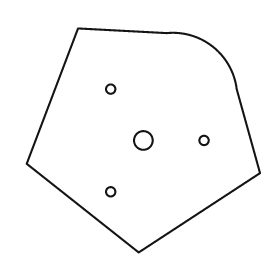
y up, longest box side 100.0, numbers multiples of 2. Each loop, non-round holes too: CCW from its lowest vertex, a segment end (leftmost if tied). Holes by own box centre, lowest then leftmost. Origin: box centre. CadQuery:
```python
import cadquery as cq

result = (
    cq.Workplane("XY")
    .moveTo(-2.0, -48.0)
    .lineTo(50.0, -14.0)
    .lineTo(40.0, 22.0)
    .threePointArc((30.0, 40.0), (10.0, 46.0))
    .lineTo(-28.0, 48.0)
    .lineTo(-50.0, -10.0)
    .close()
    .moveTo(-14.0, -22.0)
    .circle(2.0)
    .moveTo(0.0, 0.0)
    .circle(4.0)
    .moveTo(26.0, 0.0)
    .circle(2.0)
    .moveTo(-14.0, 22.0)
    .circle(2.0)
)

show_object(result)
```